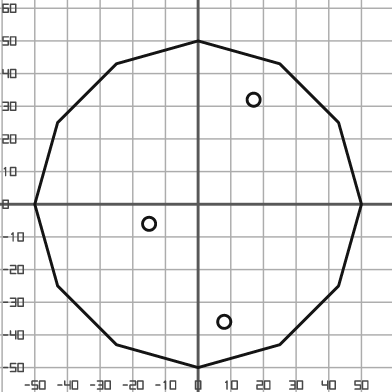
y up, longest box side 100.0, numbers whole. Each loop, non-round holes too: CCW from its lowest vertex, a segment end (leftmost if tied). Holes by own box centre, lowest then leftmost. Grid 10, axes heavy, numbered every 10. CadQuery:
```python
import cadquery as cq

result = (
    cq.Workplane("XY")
    .moveTo(0.0, -50.0)
    .lineTo(25.0, -43.0)
    .lineTo(43.0, -25.0)
    .lineTo(50.0, 0.0)
    .lineTo(43.0, 25.0)
    .lineTo(25.0, 43.0)
    .lineTo(0.0, 50.0)
    .lineTo(-25.0, 43.0)
    .lineTo(-43.0, 25.0)
    .lineTo(-50.0, 0.0)
    .lineTo(-43.0, -25.0)
    .lineTo(-25.0, -43.0)
    .close()
    .moveTo(8.0, -36.0)
    .circle(2.0)
    .moveTo(-15.0, -6.0)
    .circle(2.0)
    .moveTo(17.0, 32.0)
    .circle(2.0)
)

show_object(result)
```